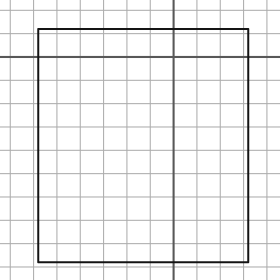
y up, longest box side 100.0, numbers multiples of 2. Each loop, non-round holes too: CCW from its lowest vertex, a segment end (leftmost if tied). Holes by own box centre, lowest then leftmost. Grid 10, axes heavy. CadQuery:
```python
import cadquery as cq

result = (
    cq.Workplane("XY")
    .moveTo(-58.0, -88.0)
    .lineTo(32.0, -88.0)
    .lineTo(32.0, 12.0)
    .lineTo(-58.0, 12.0)
    .close()
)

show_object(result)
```